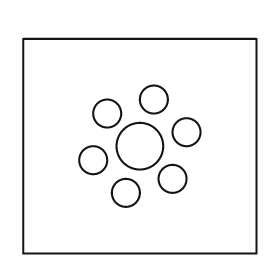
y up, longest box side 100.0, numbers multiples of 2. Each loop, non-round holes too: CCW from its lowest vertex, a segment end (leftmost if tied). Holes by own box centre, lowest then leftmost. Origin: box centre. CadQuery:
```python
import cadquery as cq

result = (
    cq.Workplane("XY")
    .moveTo(-50.0, -46.0)
    .lineTo(50.0, -46.0)
    .lineTo(50.0, 46.0)
    .lineTo(-50.0, 46.0)
    .close()
    .moveTo(-6.0, -20.0)
    .circle(6.0)
    .moveTo(14.0, -14.0)
    .circle(6.0)
    .moveTo(-20.0, -6.0)
    .circle(6.0)
    .moveTo(0.0, 0.0)
    .circle(10.0)
    .moveTo(20.0, 6.0)
    .circle(6.0)
    .moveTo(-14.0, 14.0)
    .circle(6.0)
    .moveTo(6.0, 20.0)
    .circle(6.0)
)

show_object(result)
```